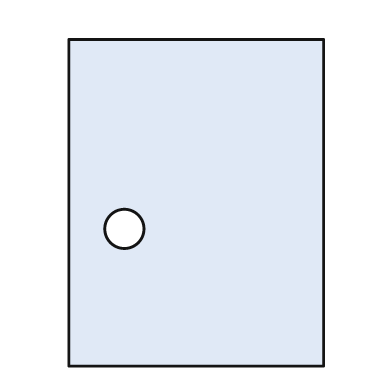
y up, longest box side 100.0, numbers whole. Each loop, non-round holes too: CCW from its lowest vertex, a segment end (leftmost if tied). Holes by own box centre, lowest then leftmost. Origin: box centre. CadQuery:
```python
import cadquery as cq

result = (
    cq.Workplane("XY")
    .moveTo(-39.0, -50.0)
    .lineTo(39.0, -50.0)
    .lineTo(39.0, 50.0)
    .lineTo(-39.0, 50.0)
    .close()
    .moveTo(-22.0, -8.0)
    .circle(6.0)
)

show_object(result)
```